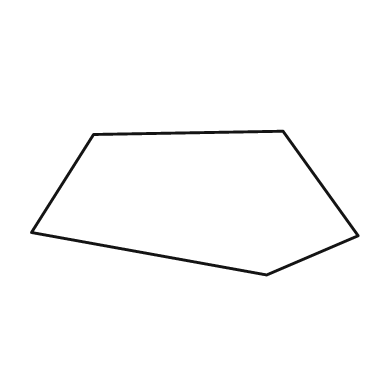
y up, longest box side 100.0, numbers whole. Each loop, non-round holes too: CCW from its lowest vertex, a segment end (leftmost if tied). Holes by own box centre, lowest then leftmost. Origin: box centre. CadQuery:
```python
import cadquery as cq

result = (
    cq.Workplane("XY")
    .moveTo(22.0, -22.0)
    .lineTo(50.0, -10.0)
    .lineTo(27.0, 22.0)
    .lineTo(-31.0, 21.0)
    .lineTo(-50.0, -9.0)
    .close()
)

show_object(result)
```